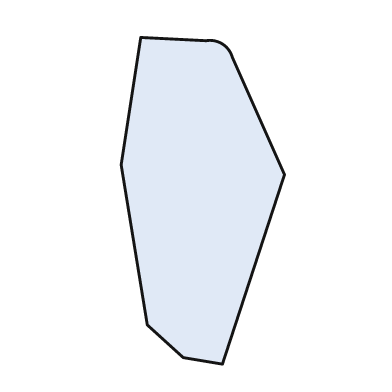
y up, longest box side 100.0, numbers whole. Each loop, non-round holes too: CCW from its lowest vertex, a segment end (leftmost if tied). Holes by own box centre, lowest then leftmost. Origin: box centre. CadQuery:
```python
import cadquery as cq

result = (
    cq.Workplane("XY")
    .moveTo(6.0, -50.0)
    .lineTo(25.0, 8.0)
    .lineTo(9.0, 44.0)
    .threePointArc((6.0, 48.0), (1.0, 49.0))
    .lineTo(-19.0, 50.0)
    .lineTo(-25.0, 11.0)
    .lineTo(-17.0, -38.0)
    .lineTo(-6.0, -48.0)
    .close()
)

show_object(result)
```